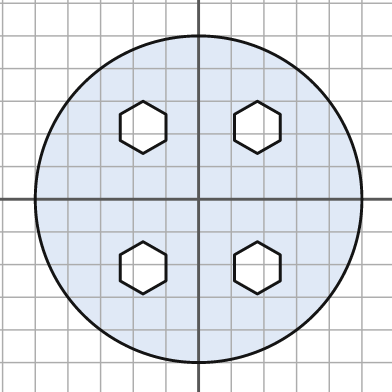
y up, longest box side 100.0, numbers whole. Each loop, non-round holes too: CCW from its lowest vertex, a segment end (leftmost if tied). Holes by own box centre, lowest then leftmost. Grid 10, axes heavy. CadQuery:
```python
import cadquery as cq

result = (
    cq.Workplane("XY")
    .moveTo(0.0, 0.0)
    .circle(50.0)
    .moveTo(-17.0, -29.0)
    .lineTo(-10.0, -25.0)
    .lineTo(-10.0, -17.0)
    .lineTo(-17.0, -13.0)
    .lineTo(-24.0, -17.0)
    .lineTo(-24.0, -25.0)
    .close()
    .moveTo(18.0, -29.0)
    .lineTo(25.0, -25.0)
    .lineTo(25.0, -17.0)
    .lineTo(18.0, -13.0)
    .lineTo(11.0, -17.0)
    .lineTo(11.0, -25.0)
    .close()
    .moveTo(-17.0, 14.0)
    .lineTo(-10.0, 18.0)
    .lineTo(-10.0, 26.0)
    .lineTo(-17.0, 30.0)
    .lineTo(-24.0, 26.0)
    .lineTo(-24.0, 18.0)
    .close()
    .moveTo(18.0, 14.0)
    .lineTo(25.0, 18.0)
    .lineTo(25.0, 26.0)
    .lineTo(18.0, 30.0)
    .lineTo(11.0, 26.0)
    .lineTo(11.0, 18.0)
    .close()
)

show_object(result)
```